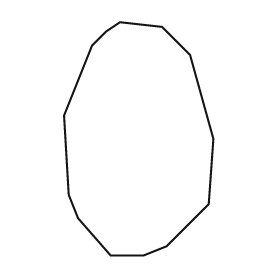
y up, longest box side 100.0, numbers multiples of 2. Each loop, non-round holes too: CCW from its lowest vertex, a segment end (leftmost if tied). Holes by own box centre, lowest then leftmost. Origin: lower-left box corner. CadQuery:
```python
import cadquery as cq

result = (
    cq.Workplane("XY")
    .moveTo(20.0, 0.0)
    .lineTo(34.0, 0.0)
    .lineTo(44.0, 4.0)
    .lineTo(62.0, 22.0)
    .lineTo(64.0, 50.0)
    .lineTo(54.0, 86.0)
    .lineTo(42.0, 98.0)
    .lineTo(24.0, 100.0)
    .lineTo(18.0, 96.0)
    .lineTo(12.0, 90.0)
    .lineTo(0.0, 60.0)
    .lineTo(2.0, 26.0)
    .lineTo(6.0, 16.0)
    .close()
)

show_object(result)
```